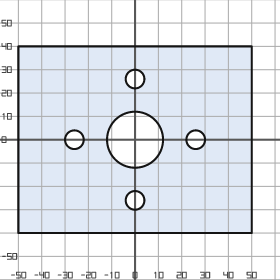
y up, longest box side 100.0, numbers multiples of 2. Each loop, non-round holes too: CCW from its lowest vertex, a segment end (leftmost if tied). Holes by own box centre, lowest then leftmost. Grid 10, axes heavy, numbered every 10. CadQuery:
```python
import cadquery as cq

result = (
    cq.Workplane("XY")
    .moveTo(-50.0, -40.0)
    .lineTo(50.0, -40.0)
    .lineTo(50.0, 40.0)
    .lineTo(-50.0, 40.0)
    .close()
    .moveTo(0.0, -26.0)
    .circle(4.0)
    .moveTo(-26.0, 0.0)
    .circle(4.0)
    .moveTo(0.0, 0.0)
    .circle(12.0)
    .moveTo(26.0, 0.0)
    .circle(4.0)
    .moveTo(0.0, 26.0)
    .circle(4.0)
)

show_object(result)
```